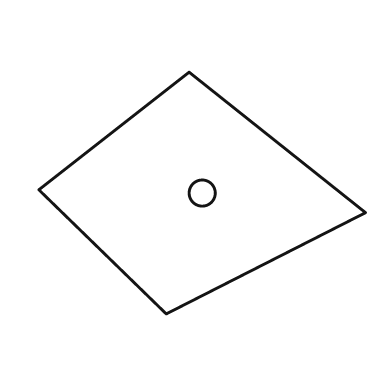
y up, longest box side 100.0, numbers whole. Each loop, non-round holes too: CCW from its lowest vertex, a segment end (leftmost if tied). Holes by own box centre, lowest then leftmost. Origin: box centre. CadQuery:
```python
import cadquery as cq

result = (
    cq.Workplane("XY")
    .moveTo(-11.0, -37.0)
    .lineTo(50.0, -6.0)
    .lineTo(-4.0, 37.0)
    .lineTo(-50.0, 1.0)
    .close()
    .moveTo(0.0, 0.0)
    .circle(4.0)
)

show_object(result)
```